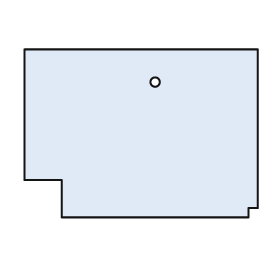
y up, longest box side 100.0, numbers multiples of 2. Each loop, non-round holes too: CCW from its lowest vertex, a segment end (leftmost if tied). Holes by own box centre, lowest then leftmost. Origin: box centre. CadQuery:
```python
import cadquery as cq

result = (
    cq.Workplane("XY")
    .moveTo(-34.0, -36.0)
    .lineTo(46.0, -36.0)
    .lineTo(46.0, -32.0)
    .lineTo(50.0, -32.0)
    .lineTo(50.0, 36.0)
    .lineTo(-50.0, 36.0)
    .lineTo(-50.0, -20.0)
    .lineTo(-34.0, -20.0)
    .close()
    .moveTo(6.0, 22.0)
    .circle(2.0)
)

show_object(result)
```